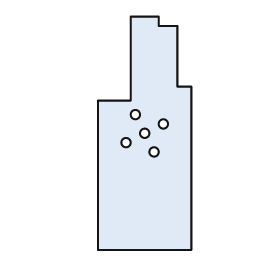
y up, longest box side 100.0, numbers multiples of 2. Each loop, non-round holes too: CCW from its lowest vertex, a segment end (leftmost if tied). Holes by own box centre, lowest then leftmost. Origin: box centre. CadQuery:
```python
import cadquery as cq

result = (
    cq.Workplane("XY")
    .moveTo(-20.0, -50.0)
    .lineTo(20.0, -50.0)
    .lineTo(20.0, 20.0)
    .lineTo(14.0, 20.0)
    .lineTo(14.0, 46.0)
    .lineTo(6.0, 46.0)
    .lineTo(6.0, 50.0)
    .lineTo(-6.0, 50.0)
    .lineTo(-6.0, 14.0)
    .lineTo(-20.0, 14.0)
    .close()
    .moveTo(4.0, -8.0)
    .circle(2.0)
    .moveTo(-8.0, -4.0)
    .circle(2.0)
    .moveTo(0.0, 0.0)
    .circle(2.0)
    .moveTo(8.0, 4.0)
    .circle(2.0)
    .moveTo(-4.0, 8.0)
    .circle(2.0)
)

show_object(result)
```